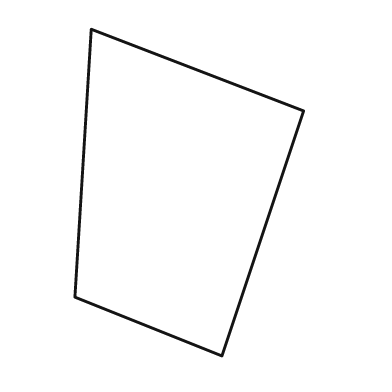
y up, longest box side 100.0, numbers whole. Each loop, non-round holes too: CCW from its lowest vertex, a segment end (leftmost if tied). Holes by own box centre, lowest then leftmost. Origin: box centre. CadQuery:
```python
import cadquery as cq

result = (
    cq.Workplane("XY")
    .moveTo(10.0, -50.0)
    .lineTo(35.0, 25.0)
    .lineTo(-30.0, 50.0)
    .lineTo(-35.0, -32.0)
    .close()
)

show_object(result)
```